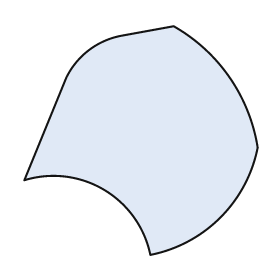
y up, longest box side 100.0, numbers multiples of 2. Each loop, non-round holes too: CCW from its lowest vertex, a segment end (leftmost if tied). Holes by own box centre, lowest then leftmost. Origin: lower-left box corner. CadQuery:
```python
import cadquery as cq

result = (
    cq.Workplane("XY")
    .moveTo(54.0, 0.0)
    .threePointArc((84.0, 16.0), (100.0, 46.0))
    .threePointArc((88.0, 76.0), (64.0, 98.0))
    .lineTo(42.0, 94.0)
    .threePointArc((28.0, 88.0), (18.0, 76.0))
    .lineTo(0.0, 32.0)
    .threePointArc((34.0, 28.0), (54.0, 0.0))
    .close()
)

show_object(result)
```